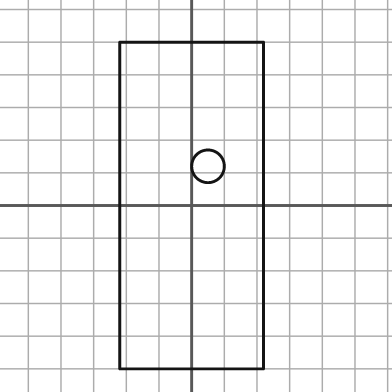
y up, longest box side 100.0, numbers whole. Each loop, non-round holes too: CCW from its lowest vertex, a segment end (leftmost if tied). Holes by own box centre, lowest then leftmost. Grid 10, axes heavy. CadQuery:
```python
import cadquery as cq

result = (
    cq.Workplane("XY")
    .moveTo(-22.0, -50.0)
    .lineTo(22.0, -50.0)
    .lineTo(22.0, 50.0)
    .lineTo(-22.0, 50.0)
    .close()
    .moveTo(5.0, 12.0)
    .circle(5.0)
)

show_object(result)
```